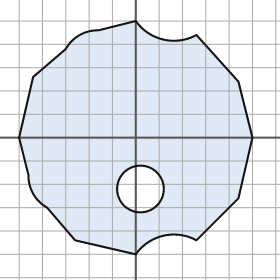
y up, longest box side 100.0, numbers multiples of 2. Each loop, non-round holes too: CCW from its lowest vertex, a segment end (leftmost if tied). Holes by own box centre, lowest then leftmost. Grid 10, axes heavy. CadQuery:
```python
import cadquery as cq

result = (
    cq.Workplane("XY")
    .moveTo(0.0, -50.0)
    .threePointArc((12.0, -42.0), (26.0, -44.0))
    .lineTo(44.0, -26.0)
    .lineTo(50.0, 0.0)
    .lineTo(44.0, 24.0)
    .lineTo(26.0, 44.0)
    .threePointArc((12.0, 42.0), (0.0, 50.0))
    .lineTo(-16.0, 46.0)
    .threePointArc((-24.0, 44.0), (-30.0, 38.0))
    .lineTo(-44.0, 26.0)
    .lineTo(-50.0, 0.0)
    .lineTo(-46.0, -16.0)
    .threePointArc((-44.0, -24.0), (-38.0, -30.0))
    .lineTo(-26.0, -44.0)
    .close()
    .moveTo(2.0, -22.0)
    .circle(10.0)
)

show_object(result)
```